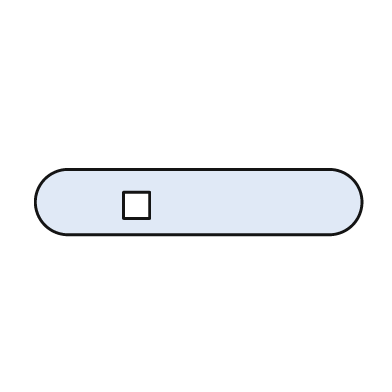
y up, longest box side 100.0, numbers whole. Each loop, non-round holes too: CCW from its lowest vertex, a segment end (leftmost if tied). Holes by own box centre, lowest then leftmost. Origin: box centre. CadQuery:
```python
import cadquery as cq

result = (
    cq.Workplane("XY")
    .moveTo(-40.0, -10.0)
    .lineTo(40.0, -10.0)
    .threePointArc((50.0, 0.0), (40.0, 10.0))
    .lineTo(-40.0, 10.0)
    .threePointArc((-50.0, 0.0), (-40.0, -10.0))
    .close()
    .moveTo(-23.0, -5.0)
    .lineTo(-15.0, -5.0)
    .lineTo(-15.0, 3.0)
    .lineTo(-23.0, 3.0)
    .close()
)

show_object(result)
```